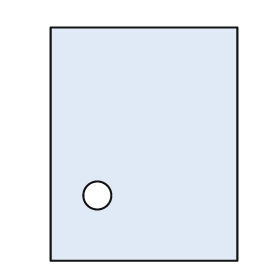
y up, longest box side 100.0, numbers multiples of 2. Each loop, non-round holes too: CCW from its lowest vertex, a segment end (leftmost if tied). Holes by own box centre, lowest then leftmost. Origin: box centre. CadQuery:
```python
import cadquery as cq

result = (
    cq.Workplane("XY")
    .moveTo(-40.0, -50.0)
    .lineTo(40.0, -50.0)
    .lineTo(40.0, 50.0)
    .lineTo(-40.0, 50.0)
    .close()
    .moveTo(-20.0, -22.0)
    .circle(6.0)
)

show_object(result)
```